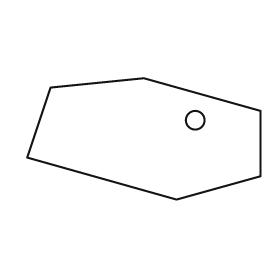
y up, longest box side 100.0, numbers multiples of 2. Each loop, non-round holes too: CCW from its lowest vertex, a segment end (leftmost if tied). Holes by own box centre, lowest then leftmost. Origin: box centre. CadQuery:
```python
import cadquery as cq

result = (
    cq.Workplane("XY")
    .moveTo(14.0, -26.0)
    .lineTo(50.0, -16.0)
    .lineTo(50.0, 12.0)
    .lineTo(0.0, 26.0)
    .lineTo(-40.0, 22.0)
    .lineTo(-50.0, -8.0)
    .close()
    .moveTo(22.0, 8.0)
    .circle(4.0)
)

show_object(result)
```